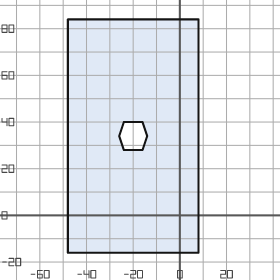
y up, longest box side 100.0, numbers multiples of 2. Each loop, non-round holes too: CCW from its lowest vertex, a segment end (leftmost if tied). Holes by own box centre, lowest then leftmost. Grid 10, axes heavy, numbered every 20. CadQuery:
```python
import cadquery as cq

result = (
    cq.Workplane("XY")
    .moveTo(-48.0, -16.0)
    .lineTo(8.0, -16.0)
    .lineTo(8.0, 84.0)
    .lineTo(-48.0, 84.0)
    .close()
    .moveTo(-24.0, 28.0)
    .lineTo(-16.0, 28.0)
    .lineTo(-14.0, 34.0)
    .lineTo(-16.0, 40.0)
    .lineTo(-24.0, 40.0)
    .lineTo(-26.0, 34.0)
    .close()
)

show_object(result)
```